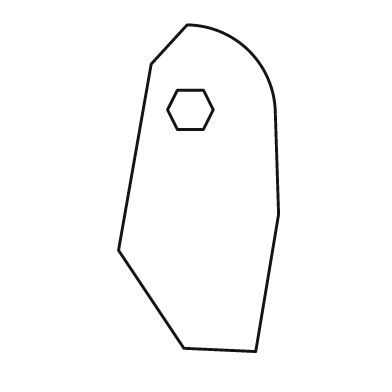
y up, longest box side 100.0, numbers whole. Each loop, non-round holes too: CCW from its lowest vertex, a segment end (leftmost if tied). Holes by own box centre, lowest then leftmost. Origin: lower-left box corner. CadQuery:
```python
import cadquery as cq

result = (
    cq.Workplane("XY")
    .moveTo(42.0, 0.0)
    .lineTo(49.0, 42.0)
    .lineTo(48.0, 73.0)
    .threePointArc((40.0, 92.0), (21.0, 100.0))
    .lineTo(10.0, 88.0)
    .lineTo(0.0, 31.0)
    .lineTo(20.0, 1.0)
    .close()
    .moveTo(18.0, 68.0)
    .lineTo(26.0, 68.0)
    .lineTo(29.0, 74.0)
    .lineTo(26.0, 80.0)
    .lineTo(18.0, 80.0)
    .lineTo(15.0, 74.0)
    .close()
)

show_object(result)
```